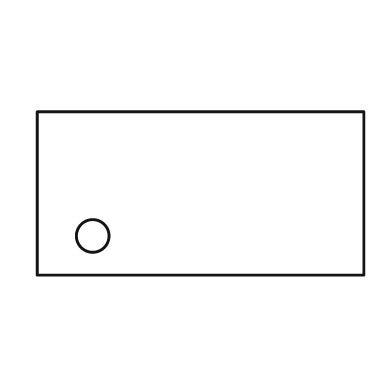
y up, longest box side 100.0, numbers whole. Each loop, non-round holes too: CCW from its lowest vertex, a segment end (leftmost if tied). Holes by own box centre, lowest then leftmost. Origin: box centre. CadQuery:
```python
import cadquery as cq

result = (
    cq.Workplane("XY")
    .moveTo(-50.0, -25.0)
    .lineTo(50.0, -25.0)
    .lineTo(50.0, 25.0)
    .lineTo(-50.0, 25.0)
    .close()
    .moveTo(-33.0, -13.0)
    .circle(5.0)
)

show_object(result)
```